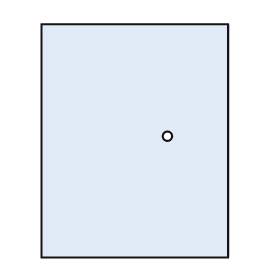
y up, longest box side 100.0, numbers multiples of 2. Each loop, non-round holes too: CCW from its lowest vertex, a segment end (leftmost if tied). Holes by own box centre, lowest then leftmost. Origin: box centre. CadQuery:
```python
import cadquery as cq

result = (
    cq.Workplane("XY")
    .moveTo(-40.0, -50.0)
    .lineTo(40.0, -50.0)
    .lineTo(40.0, 50.0)
    .lineTo(-40.0, 50.0)
    .close()
    .moveTo(14.0, 2.0)
    .circle(2.0)
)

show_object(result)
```